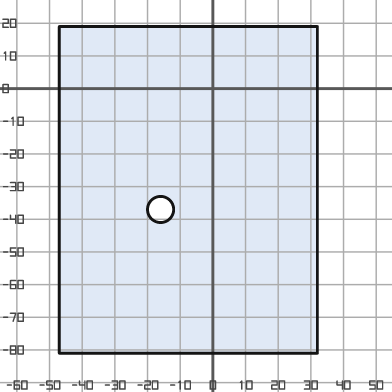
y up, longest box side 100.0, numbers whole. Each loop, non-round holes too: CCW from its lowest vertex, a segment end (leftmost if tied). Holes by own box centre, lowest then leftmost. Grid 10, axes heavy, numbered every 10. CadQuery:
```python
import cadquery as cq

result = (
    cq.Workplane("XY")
    .moveTo(-47.0, -81.0)
    .lineTo(32.0, -81.0)
    .lineTo(32.0, 19.0)
    .lineTo(-47.0, 19.0)
    .close()
    .moveTo(-16.0, -37.0)
    .circle(4.0)
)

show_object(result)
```